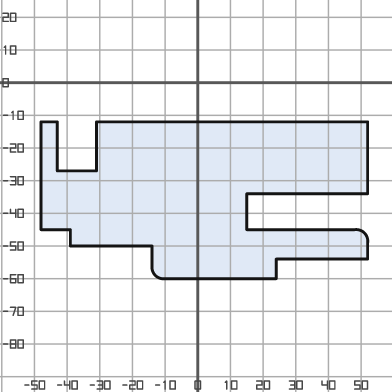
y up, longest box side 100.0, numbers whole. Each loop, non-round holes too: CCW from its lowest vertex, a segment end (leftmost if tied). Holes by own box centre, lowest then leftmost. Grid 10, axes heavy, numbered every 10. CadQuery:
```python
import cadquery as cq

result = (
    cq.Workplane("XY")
    .moveTo(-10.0, -60.0)
    .lineTo(24.0, -60.0)
    .lineTo(24.0, -54.0)
    .lineTo(52.0, -54.0)
    .lineTo(52.0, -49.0)
    .threePointArc((51.0, -46.0), (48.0, -45.0))
    .lineTo(15.0, -45.0)
    .lineTo(15.0, -34.0)
    .lineTo(52.0, -34.0)
    .lineTo(52.0, -12.0)
    .lineTo(-31.0, -12.0)
    .lineTo(-31.0, -27.0)
    .lineTo(-43.0, -27.0)
    .lineTo(-43.0, -12.0)
    .lineTo(-48.0, -12.0)
    .lineTo(-48.0, -45.0)
    .lineTo(-39.0, -45.0)
    .lineTo(-39.0, -50.0)
    .lineTo(-14.0, -50.0)
    .lineTo(-14.0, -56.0)
    .threePointArc((-13.0, -59.0), (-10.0, -60.0))
    .close()
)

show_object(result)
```